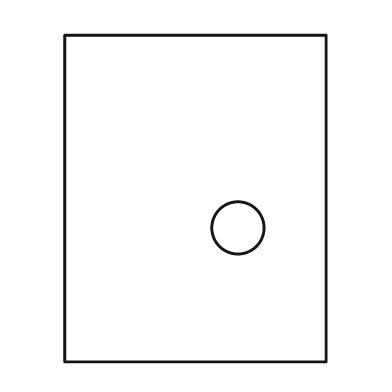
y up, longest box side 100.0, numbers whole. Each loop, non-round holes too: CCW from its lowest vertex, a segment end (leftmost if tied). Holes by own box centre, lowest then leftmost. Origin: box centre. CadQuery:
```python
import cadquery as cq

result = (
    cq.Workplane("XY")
    .moveTo(-40.0, -50.0)
    .lineTo(40.0, -50.0)
    .lineTo(40.0, 50.0)
    .lineTo(-40.0, 50.0)
    .close()
    .moveTo(13.0, -9.0)
    .circle(8.0)
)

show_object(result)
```